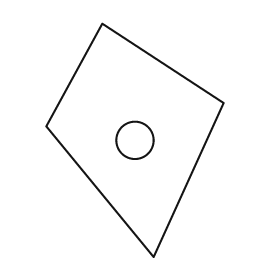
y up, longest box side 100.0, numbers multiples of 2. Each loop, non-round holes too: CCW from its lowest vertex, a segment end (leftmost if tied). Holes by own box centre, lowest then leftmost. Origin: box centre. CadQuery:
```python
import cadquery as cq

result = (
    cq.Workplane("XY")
    .moveTo(8.0, -50.0)
    .lineTo(38.0, 16.0)
    .lineTo(-14.0, 50.0)
    .lineTo(-38.0, 6.0)
    .close()
    .moveTo(0.0, 0.0)
    .circle(8.0)
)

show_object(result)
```